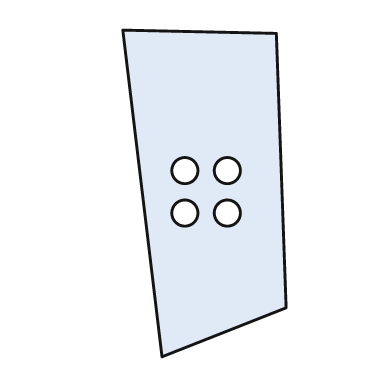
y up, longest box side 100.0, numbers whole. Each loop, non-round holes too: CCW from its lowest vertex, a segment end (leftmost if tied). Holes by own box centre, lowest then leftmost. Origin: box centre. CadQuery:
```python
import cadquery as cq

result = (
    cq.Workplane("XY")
    .moveTo(-13.0, -50.0)
    .lineTo(25.0, -35.0)
    .lineTo(22.0, 49.0)
    .lineTo(-25.0, 50.0)
    .close()
    .moveTo(-6.0, -6.0)
    .circle(4.0)
    .moveTo(7.0, -6.0)
    .circle(4.0)
    .moveTo(-6.0, 7.0)
    .circle(4.0)
    .moveTo(7.0, 7.0)
    .circle(4.0)
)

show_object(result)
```